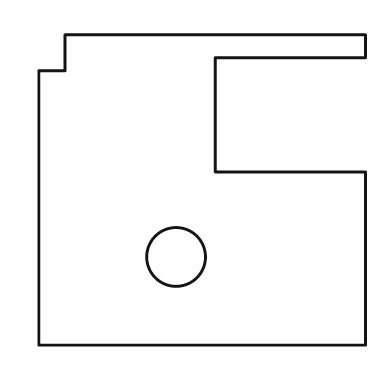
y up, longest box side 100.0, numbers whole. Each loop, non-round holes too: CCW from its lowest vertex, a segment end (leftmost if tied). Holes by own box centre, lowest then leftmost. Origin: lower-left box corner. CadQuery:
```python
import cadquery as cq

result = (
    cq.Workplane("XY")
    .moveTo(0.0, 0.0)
    .lineTo(100.0, 0.0)
    .lineTo(100.0, 53.0)
    .lineTo(54.0, 53.0)
    .lineTo(54.0, 88.0)
    .lineTo(100.0, 88.0)
    .lineTo(100.0, 95.0)
    .lineTo(8.0, 95.0)
    .lineTo(8.0, 84.0)
    .lineTo(0.0, 84.0)
    .close()
    .moveTo(42.0, 27.0)
    .circle(9.0)
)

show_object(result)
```